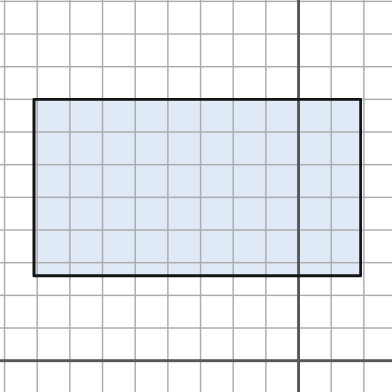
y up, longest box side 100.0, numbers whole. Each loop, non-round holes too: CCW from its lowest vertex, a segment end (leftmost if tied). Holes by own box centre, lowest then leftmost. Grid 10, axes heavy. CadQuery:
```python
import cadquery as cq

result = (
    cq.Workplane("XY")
    .moveTo(-81.0, 26.0)
    .lineTo(19.0, 26.0)
    .lineTo(19.0, 80.0)
    .lineTo(-81.0, 80.0)
    .close()
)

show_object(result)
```